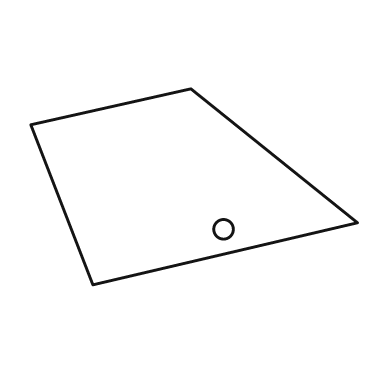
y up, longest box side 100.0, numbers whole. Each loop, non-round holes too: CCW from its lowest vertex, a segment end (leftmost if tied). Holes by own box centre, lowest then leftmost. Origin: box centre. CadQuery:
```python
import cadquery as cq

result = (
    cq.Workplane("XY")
    .moveTo(-31.0, -30.0)
    .lineTo(50.0, -11.0)
    .lineTo(-1.0, 30.0)
    .lineTo(-50.0, 19.0)
    .close()
    .moveTo(9.0, -13.0)
    .circle(3.0)
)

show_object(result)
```